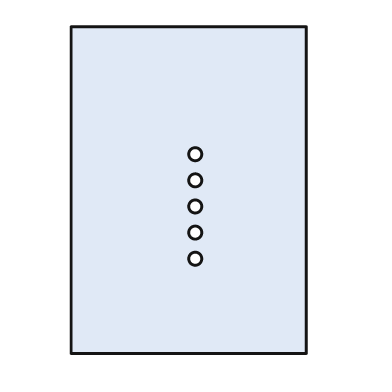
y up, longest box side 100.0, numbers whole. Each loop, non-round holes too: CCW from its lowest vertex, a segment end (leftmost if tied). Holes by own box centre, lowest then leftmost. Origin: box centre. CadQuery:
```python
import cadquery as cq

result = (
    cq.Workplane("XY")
    .moveTo(-36.0, -50.0)
    .lineTo(36.0, -50.0)
    .lineTo(36.0, 50.0)
    .lineTo(-36.0, 50.0)
    .close()
    .moveTo(2.0, -21.0)
    .circle(2.0)
    .moveTo(2.0, -13.0)
    .circle(2.0)
    .moveTo(2.0, -5.0)
    .circle(2.0)
    .moveTo(2.0, 3.0)
    .circle(2.0)
    .moveTo(2.0, 11.0)
    .circle(2.0)
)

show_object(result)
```